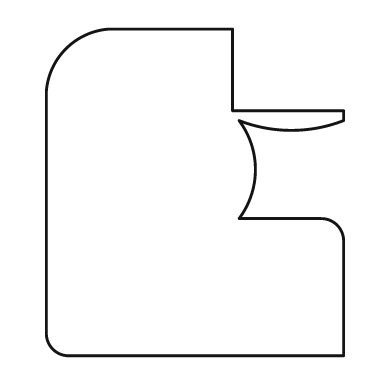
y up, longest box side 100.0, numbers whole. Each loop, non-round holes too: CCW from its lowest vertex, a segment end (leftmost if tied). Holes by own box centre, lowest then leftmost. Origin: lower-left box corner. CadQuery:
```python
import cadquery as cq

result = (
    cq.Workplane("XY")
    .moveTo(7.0, 0.0)
    .lineTo(91.0, 0.0)
    .lineTo(91.0, 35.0)
    .threePointArc((89.0, 40.0), (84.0, 42.0))
    .lineTo(59.0, 42.0)
    .threePointArc((64.0, 57.0), (59.0, 72.0))
    .threePointArc((75.0, 69.0), (91.0, 72.0))
    .lineTo(91.0, 75.0)
    .lineTo(57.0, 75.0)
    .lineTo(57.0, 100.0)
    .lineTo(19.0, 100.0)
    .threePointArc((6.0, 94.0), (0.0, 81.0))
    .lineTo(0.0, 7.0)
    .threePointArc((2.0, 2.0), (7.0, 0.0))
    .close()
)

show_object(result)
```